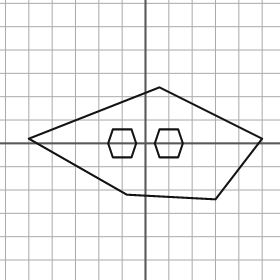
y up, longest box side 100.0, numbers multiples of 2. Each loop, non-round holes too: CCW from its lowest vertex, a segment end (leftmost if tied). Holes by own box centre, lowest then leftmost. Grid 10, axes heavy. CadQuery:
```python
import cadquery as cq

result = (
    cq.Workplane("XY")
    .moveTo(30.0, -24.0)
    .lineTo(50.0, 2.0)
    .lineTo(6.0, 24.0)
    .lineTo(-50.0, 2.0)
    .lineTo(-8.0, -22.0)
    .close()
    .moveTo(-14.0, -6.0)
    .lineTo(-6.0, -6.0)
    .lineTo(-4.0, 0.0)
    .lineTo(-6.0, 6.0)
    .lineTo(-14.0, 6.0)
    .lineTo(-16.0, 0.0)
    .close()
    .moveTo(6.0, -6.0)
    .lineTo(14.0, -6.0)
    .lineTo(16.0, 0.0)
    .lineTo(14.0, 6.0)
    .lineTo(6.0, 6.0)
    .lineTo(4.0, 0.0)
    .close()
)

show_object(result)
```